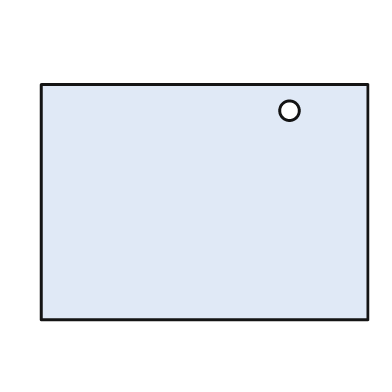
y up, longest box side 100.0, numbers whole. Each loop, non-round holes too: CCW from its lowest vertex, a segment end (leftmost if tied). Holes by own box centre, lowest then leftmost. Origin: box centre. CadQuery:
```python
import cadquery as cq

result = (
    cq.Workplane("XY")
    .moveTo(-50.0, -36.0)
    .lineTo(50.0, -36.0)
    .lineTo(50.0, 36.0)
    .lineTo(-50.0, 36.0)
    .close()
    .moveTo(26.0, 28.0)
    .circle(3.0)
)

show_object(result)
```